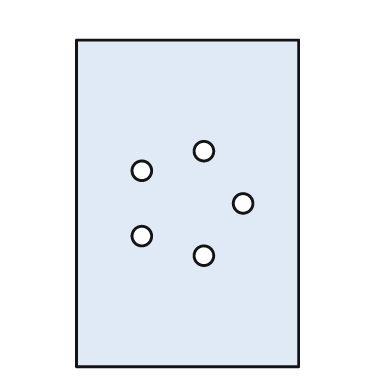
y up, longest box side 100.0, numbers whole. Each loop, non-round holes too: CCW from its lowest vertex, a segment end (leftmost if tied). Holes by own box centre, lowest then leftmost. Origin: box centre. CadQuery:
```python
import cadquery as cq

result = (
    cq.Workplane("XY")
    .moveTo(-34.0, -50.0)
    .lineTo(34.0, -50.0)
    .lineTo(34.0, 50.0)
    .lineTo(-34.0, 50.0)
    .close()
    .moveTo(5.0, -16.0)
    .circle(3.0)
    .moveTo(-14.0, -10.0)
    .circle(3.0)
    .moveTo(17.0, 0.0)
    .circle(3.0)
    .moveTo(-14.0, 10.0)
    .circle(3.0)
    .moveTo(5.0, 16.0)
    .circle(3.0)
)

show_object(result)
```